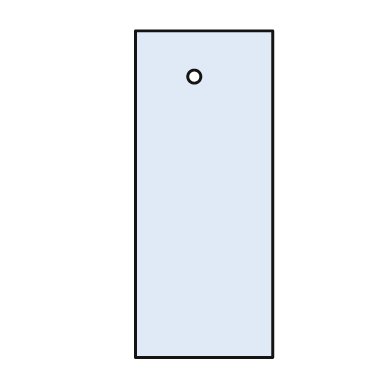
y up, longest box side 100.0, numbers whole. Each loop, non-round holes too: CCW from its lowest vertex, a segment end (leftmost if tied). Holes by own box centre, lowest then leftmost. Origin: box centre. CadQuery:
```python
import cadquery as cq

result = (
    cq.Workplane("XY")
    .moveTo(-21.0, -50.0)
    .lineTo(21.0, -50.0)
    .lineTo(21.0, 50.0)
    .lineTo(-21.0, 50.0)
    .close()
    .moveTo(-3.0, 36.0)
    .circle(2.0)
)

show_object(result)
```